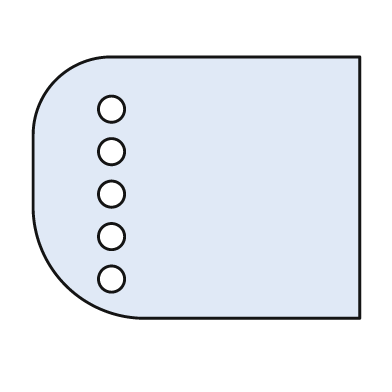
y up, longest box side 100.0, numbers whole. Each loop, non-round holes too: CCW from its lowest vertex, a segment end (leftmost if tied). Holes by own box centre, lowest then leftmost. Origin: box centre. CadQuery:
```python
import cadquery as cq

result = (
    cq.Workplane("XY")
    .moveTo(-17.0, -40.0)
    .lineTo(50.0, -40.0)
    .lineTo(50.0, 40.0)
    .lineTo(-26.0, 40.0)
    .threePointArc((-43.0, 33.0), (-50.0, 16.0))
    .lineTo(-50.0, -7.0)
    .threePointArc((-40.0, -30.0), (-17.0, -40.0))
    .close()
    .moveTo(-26.0, -28.0)
    .circle(4.0)
    .moveTo(-26.0, -15.0)
    .circle(4.0)
    .moveTo(-26.0, -2.0)
    .circle(4.0)
    .moveTo(-26.0, 11.0)
    .circle(4.0)
    .moveTo(-26.0, 24.0)
    .circle(4.0)
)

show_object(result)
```